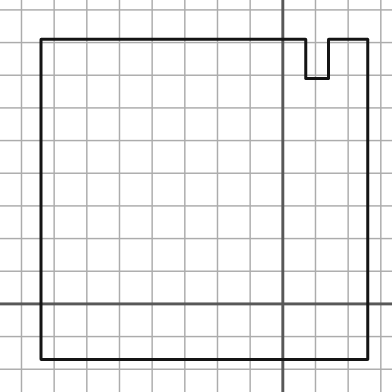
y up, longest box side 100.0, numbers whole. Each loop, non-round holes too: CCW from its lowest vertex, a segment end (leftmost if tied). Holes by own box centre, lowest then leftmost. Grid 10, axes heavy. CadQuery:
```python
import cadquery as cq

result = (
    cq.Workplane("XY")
    .moveTo(-74.0, -17.0)
    .lineTo(26.0, -17.0)
    .lineTo(26.0, 81.0)
    .lineTo(14.0, 81.0)
    .lineTo(14.0, 69.0)
    .lineTo(7.0, 69.0)
    .lineTo(7.0, 81.0)
    .lineTo(-74.0, 81.0)
    .close()
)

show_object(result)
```